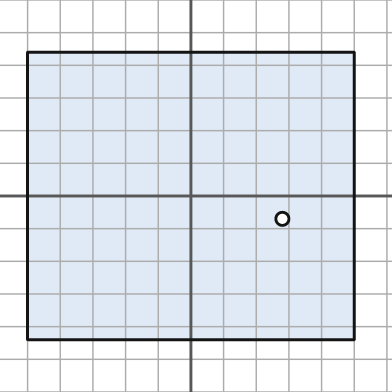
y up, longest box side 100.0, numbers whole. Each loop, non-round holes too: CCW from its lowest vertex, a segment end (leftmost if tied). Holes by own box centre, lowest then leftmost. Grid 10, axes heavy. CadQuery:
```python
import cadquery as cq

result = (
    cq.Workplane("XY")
    .moveTo(-50.0, -44.0)
    .lineTo(50.0, -44.0)
    .lineTo(50.0, 44.0)
    .lineTo(-50.0, 44.0)
    .close()
    .moveTo(28.0, -7.0)
    .circle(2.0)
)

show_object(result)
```